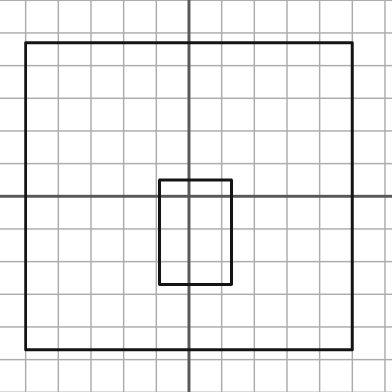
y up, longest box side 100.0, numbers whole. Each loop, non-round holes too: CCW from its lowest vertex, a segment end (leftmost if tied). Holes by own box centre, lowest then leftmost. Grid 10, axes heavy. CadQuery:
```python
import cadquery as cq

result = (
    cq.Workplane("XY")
    .moveTo(-50.0, -47.0)
    .lineTo(50.0, -47.0)
    .lineTo(50.0, 47.0)
    .lineTo(-50.0, 47.0)
    .close()
    .moveTo(-9.0, -27.0)
    .lineTo(13.0, -27.0)
    .lineTo(13.0, 5.0)
    .lineTo(-9.0, 5.0)
    .close()
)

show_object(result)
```